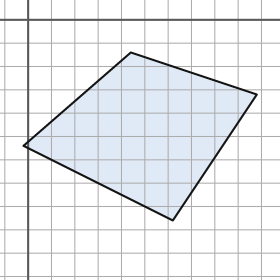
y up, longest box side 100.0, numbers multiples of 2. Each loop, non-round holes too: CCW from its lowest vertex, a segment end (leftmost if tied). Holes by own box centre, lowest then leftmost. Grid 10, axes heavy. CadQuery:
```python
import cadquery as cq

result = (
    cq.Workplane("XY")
    .moveTo(62.0, -86.0)
    .lineTo(98.0, -32.0)
    .lineTo(44.0, -14.0)
    .lineTo(-2.0, -54.0)
    .close()
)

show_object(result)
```